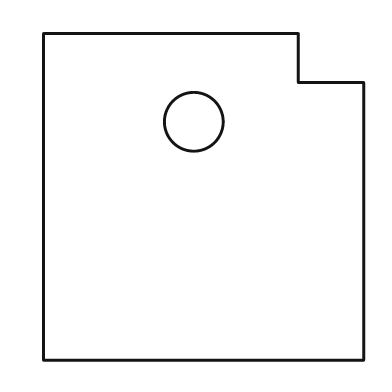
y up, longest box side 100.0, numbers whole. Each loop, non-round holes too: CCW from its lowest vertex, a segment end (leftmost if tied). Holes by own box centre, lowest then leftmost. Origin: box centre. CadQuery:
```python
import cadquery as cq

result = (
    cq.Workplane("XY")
    .moveTo(-49.0, -50.0)
    .lineTo(49.0, -50.0)
    .lineTo(49.0, 35.0)
    .lineTo(29.0, 35.0)
    .lineTo(29.0, 50.0)
    .lineTo(-49.0, 50.0)
    .close()
    .moveTo(-3.0, 23.0)
    .circle(9.0)
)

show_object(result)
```